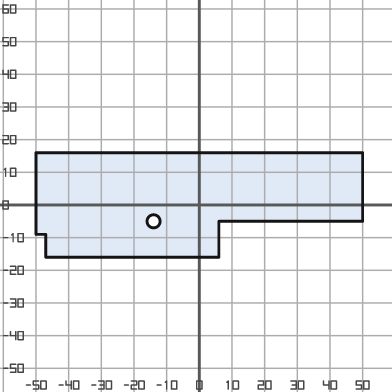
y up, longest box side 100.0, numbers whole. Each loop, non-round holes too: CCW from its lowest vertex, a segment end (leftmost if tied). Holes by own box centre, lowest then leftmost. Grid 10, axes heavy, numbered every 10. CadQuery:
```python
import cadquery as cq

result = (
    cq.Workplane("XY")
    .moveTo(-47.0, -16.0)
    .lineTo(6.0, -16.0)
    .lineTo(6.0, -5.0)
    .lineTo(50.0, -5.0)
    .lineTo(50.0, 16.0)
    .lineTo(-50.0, 16.0)
    .lineTo(-50.0, -9.0)
    .lineTo(-47.0, -9.0)
    .close()
    .moveTo(-14.0, -5.0)
    .circle(2.0)
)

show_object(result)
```